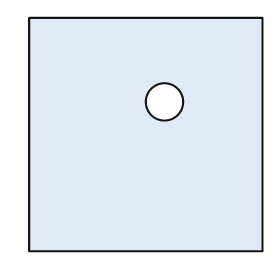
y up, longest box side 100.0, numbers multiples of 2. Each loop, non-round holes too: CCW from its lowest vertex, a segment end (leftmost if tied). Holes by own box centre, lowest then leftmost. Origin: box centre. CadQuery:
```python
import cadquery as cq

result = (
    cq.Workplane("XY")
    .moveTo(-50.0, -50.0)
    .lineTo(50.0, -50.0)
    .lineTo(50.0, 50.0)
    .lineTo(-50.0, 50.0)
    .close()
    .moveTo(8.0, 14.0)
    .circle(8.0)
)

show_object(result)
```